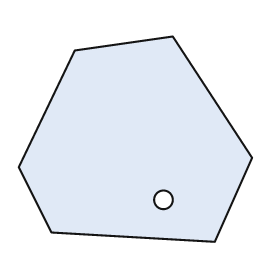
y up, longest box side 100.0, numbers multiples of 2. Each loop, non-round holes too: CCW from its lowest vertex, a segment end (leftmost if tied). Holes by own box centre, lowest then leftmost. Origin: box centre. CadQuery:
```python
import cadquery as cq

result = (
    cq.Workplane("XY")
    .moveTo(34.0, -44.0)
    .lineTo(50.0, -8.0)
    .lineTo(16.0, 44.0)
    .lineTo(-26.0, 38.0)
    .lineTo(-50.0, -12.0)
    .lineTo(-36.0, -40.0)
    .close()
    .moveTo(12.0, -26.0)
    .circle(4.0)
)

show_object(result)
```